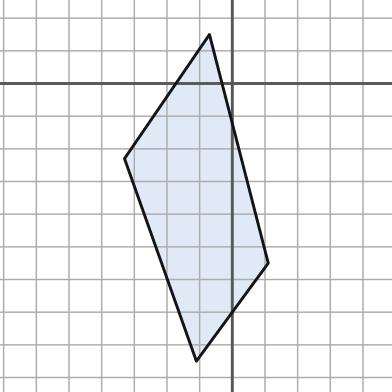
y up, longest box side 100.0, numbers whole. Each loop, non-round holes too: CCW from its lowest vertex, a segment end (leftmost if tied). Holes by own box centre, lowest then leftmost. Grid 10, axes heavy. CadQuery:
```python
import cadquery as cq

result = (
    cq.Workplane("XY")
    .moveTo(-11.0, -85.0)
    .lineTo(11.0, -55.0)
    .lineTo(-7.0, 15.0)
    .lineTo(-33.0, -23.0)
    .close()
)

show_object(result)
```